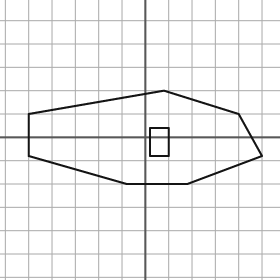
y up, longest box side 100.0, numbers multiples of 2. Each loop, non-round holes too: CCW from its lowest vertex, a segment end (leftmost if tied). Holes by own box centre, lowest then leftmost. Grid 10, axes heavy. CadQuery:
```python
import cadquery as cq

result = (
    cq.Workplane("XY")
    .moveTo(-8.0, -20.0)
    .lineTo(18.0, -20.0)
    .lineTo(50.0, -8.0)
    .lineTo(40.0, 10.0)
    .lineTo(8.0, 20.0)
    .lineTo(-50.0, 10.0)
    .lineTo(-50.0, -8.0)
    .close()
    .moveTo(2.0, -8.0)
    .lineTo(10.0, -8.0)
    .lineTo(10.0, 4.0)
    .lineTo(2.0, 4.0)
    .close()
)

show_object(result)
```